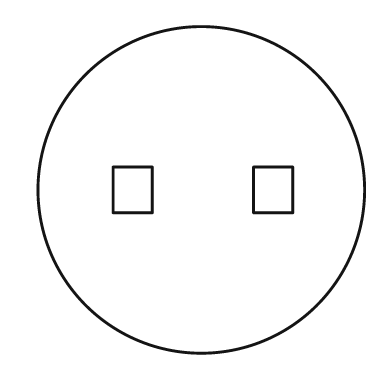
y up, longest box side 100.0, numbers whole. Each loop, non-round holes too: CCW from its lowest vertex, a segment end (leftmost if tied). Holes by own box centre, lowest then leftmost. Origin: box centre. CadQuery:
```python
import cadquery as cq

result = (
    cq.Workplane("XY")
    .moveTo(0.0, 0.0)
    .circle(50.0)
    .moveTo(-27.0, -7.0)
    .lineTo(-15.0, -7.0)
    .lineTo(-15.0, 7.0)
    .lineTo(-27.0, 7.0)
    .close()
    .moveTo(16.0, -7.0)
    .lineTo(28.0, -7.0)
    .lineTo(28.0, 7.0)
    .lineTo(16.0, 7.0)
    .close()
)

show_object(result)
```